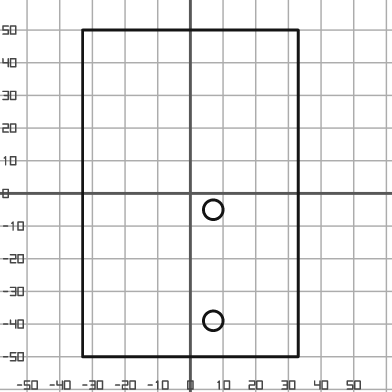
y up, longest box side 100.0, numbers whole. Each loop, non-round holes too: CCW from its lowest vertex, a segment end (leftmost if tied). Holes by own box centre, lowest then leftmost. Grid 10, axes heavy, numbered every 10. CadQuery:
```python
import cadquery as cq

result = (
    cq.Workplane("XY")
    .moveTo(-33.0, -50.0)
    .lineTo(33.0, -50.0)
    .lineTo(33.0, 50.0)
    .lineTo(-33.0, 50.0)
    .close()
    .moveTo(7.0, -39.0)
    .circle(3.0)
    .moveTo(7.0, -5.0)
    .circle(3.0)
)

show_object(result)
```